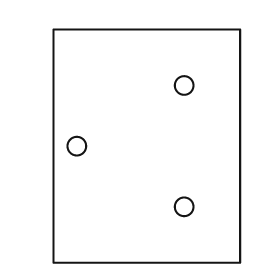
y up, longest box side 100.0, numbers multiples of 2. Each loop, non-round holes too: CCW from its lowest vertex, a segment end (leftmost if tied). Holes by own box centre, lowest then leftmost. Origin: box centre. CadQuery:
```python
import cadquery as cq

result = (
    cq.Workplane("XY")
    .moveTo(-40.0, -50.0)
    .lineTo(40.0, -50.0)
    .lineTo(40.0, 50.0)
    .lineTo(-40.0, 50.0)
    .close()
    .moveTo(16.0, -26.0)
    .circle(4.0)
    .moveTo(-30.0, 0.0)
    .circle(4.0)
    .moveTo(16.0, 26.0)
    .circle(4.0)
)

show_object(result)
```